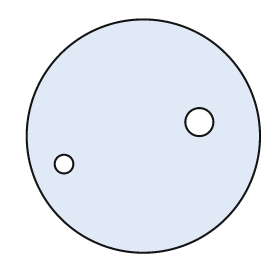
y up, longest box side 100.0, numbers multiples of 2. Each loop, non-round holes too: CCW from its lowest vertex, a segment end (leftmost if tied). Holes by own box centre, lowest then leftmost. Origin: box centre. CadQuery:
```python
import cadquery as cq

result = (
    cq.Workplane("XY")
    .moveTo(0.0, 0.0)
    .circle(50.0)
    .moveTo(-34.0, -12.0)
    .circle(4.0)
    .moveTo(24.0, 6.0)
    .circle(6.0)
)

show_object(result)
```